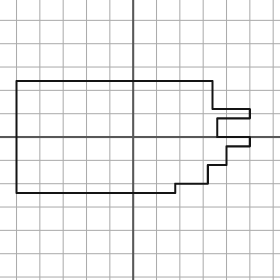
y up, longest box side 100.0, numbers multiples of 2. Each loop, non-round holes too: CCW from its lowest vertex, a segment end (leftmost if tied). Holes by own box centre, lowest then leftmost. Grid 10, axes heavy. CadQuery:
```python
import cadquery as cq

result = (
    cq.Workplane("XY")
    .moveTo(-50.0, -24.0)
    .lineTo(18.0, -24.0)
    .lineTo(18.0, -20.0)
    .lineTo(32.0, -20.0)
    .lineTo(32.0, -12.0)
    .lineTo(40.0, -12.0)
    .lineTo(40.0, -4.0)
    .lineTo(50.0, -4.0)
    .lineTo(50.0, 0.0)
    .lineTo(36.0, 0.0)
    .lineTo(36.0, 8.0)
    .lineTo(50.0, 8.0)
    .lineTo(50.0, 12.0)
    .lineTo(34.0, 12.0)
    .lineTo(34.0, 24.0)
    .lineTo(-50.0, 24.0)
    .close()
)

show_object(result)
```